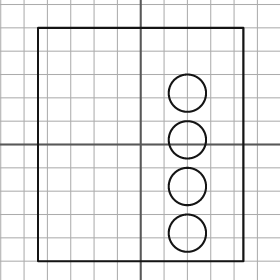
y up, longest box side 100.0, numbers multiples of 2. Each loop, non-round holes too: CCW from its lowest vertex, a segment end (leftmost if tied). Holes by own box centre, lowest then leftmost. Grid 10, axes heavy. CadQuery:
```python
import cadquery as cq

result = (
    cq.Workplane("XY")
    .moveTo(-44.0, -50.0)
    .lineTo(44.0, -50.0)
    .lineTo(44.0, 50.0)
    .lineTo(-44.0, 50.0)
    .close()
    .moveTo(20.0, -38.0)
    .circle(8.0)
    .moveTo(20.0, -18.0)
    .circle(8.0)
    .moveTo(20.0, 2.0)
    .circle(8.0)
    .moveTo(20.0, 22.0)
    .circle(8.0)
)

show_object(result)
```